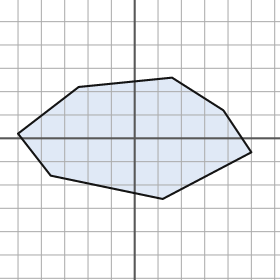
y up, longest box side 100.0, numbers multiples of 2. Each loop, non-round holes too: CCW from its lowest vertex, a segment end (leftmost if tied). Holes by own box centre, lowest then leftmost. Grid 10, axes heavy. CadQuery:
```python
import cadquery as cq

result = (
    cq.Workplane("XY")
    .moveTo(12.0, -26.0)
    .lineTo(50.0, -6.0)
    .lineTo(38.0, 12.0)
    .lineTo(16.0, 26.0)
    .lineTo(-24.0, 22.0)
    .lineTo(-50.0, 2.0)
    .lineTo(-36.0, -16.0)
    .close()
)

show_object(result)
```